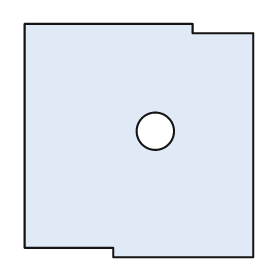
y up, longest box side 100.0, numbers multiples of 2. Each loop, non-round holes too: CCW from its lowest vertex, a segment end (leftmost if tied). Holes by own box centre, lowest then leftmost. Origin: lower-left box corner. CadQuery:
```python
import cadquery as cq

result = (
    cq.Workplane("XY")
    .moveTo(38.0, 0.0)
    .lineTo(98.0, 0.0)
    .lineTo(98.0, 96.0)
    .lineTo(72.0, 96.0)
    .lineTo(72.0, 100.0)
    .lineTo(0.0, 100.0)
    .lineTo(0.0, 4.0)
    .lineTo(38.0, 4.0)
    .close()
    .moveTo(56.0, 54.0)
    .circle(8.0)
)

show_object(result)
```